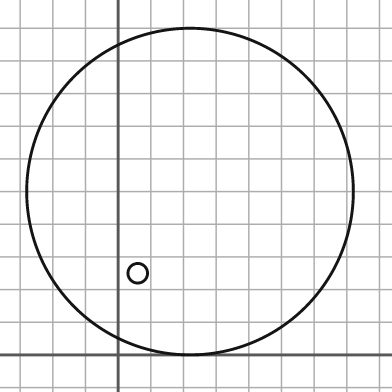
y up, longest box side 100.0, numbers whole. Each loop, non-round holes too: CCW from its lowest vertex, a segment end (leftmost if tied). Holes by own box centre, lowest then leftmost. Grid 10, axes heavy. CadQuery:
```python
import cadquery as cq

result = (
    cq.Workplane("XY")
    .moveTo(22.0, 50.0)
    .circle(50.0)
    .moveTo(6.0, 25.0)
    .circle(3.0)
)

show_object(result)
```